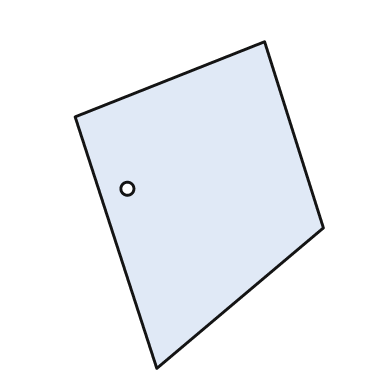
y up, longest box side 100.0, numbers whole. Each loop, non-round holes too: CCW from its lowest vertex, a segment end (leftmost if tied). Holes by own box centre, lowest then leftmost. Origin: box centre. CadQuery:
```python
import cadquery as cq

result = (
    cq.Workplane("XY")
    .moveTo(-13.0, -50.0)
    .lineTo(38.0, -7.0)
    .lineTo(20.0, 50.0)
    .lineTo(-38.0, 27.0)
    .close()
    .moveTo(-22.0, 5.0)
    .circle(2.0)
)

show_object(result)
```